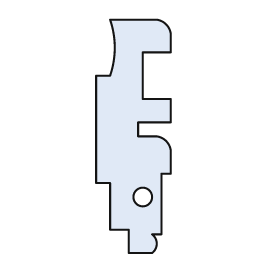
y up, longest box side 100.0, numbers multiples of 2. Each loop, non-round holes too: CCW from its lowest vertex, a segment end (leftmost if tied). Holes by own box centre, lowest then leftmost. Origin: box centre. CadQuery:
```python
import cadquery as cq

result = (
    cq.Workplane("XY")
    .moveTo(-2.0, -50.0)
    .lineTo(8.0, -50.0)
    .threePointArc((10.0, -46.0), (8.0, -42.0))
    .lineTo(12.0, -42.0)
    .lineTo(12.0, -16.0)
    .lineTo(16.0, -16.0)
    .lineTo(16.0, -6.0)
    .threePointArc((14.0, -2.0), (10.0, 0.0))
    .lineTo(2.0, 0.0)
    .lineTo(2.0, 6.0)
    .lineTo(16.0, 6.0)
    .lineTo(16.0, 16.0)
    .lineTo(4.0, 16.0)
    .lineTo(4.0, 36.0)
    .lineTo(16.0, 36.0)
    .lineTo(16.0, 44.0)
    .threePointArc((14.0, 48.0), (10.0, 50.0))
    .lineTo(-10.0, 50.0)
    .threePointArc((-8.0, 38.0), (-10.0, 26.0))
    .lineTo(-16.0, 26.0)
    .lineTo(-16.0, -20.0)
    .lineTo(-10.0, -20.0)
    .lineTo(-10.0, -40.0)
    .lineTo(-2.0, -40.0)
    .close()
    .moveTo(4.0, -26.0)
    .circle(4.0)
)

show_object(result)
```